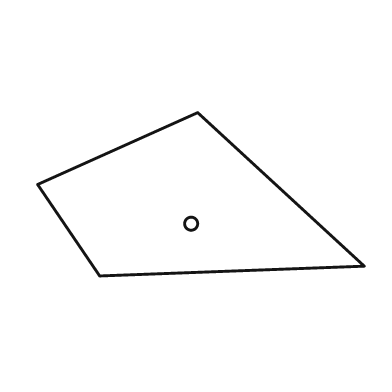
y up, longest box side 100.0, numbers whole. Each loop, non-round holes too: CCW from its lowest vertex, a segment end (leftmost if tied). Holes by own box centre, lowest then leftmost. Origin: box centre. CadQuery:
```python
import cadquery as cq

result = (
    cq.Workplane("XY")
    .moveTo(-31.0, -25.0)
    .lineTo(50.0, -22.0)
    .lineTo(-1.0, 25.0)
    .lineTo(-50.0, 3.0)
    .close()
    .moveTo(-3.0, -9.0)
    .circle(2.0)
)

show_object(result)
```